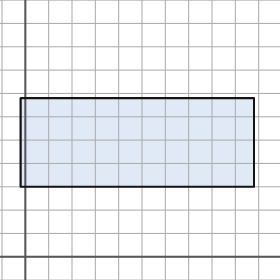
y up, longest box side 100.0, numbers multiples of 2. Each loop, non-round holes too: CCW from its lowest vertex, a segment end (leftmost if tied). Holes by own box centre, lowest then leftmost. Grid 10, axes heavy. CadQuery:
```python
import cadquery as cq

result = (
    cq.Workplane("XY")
    .moveTo(-2.0, 30.0)
    .lineTo(98.0, 30.0)
    .lineTo(98.0, 68.0)
    .lineTo(-2.0, 68.0)
    .close()
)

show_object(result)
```